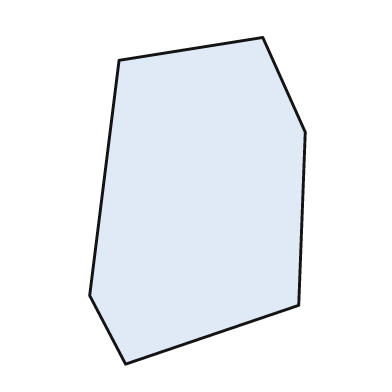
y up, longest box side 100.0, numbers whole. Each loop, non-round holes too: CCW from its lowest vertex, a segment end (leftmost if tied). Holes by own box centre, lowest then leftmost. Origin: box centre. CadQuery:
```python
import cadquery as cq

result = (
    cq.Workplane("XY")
    .moveTo(-22.0, -50.0)
    .lineTo(31.0, -32.0)
    .lineTo(33.0, 21.0)
    .lineTo(20.0, 50.0)
    .lineTo(-24.0, 43.0)
    .lineTo(-33.0, -29.0)
    .close()
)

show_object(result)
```